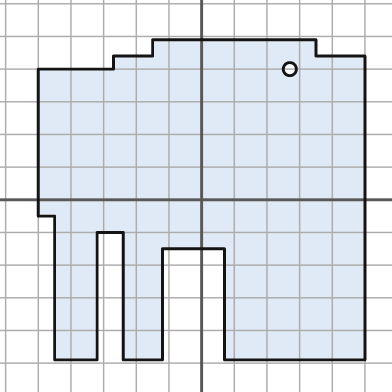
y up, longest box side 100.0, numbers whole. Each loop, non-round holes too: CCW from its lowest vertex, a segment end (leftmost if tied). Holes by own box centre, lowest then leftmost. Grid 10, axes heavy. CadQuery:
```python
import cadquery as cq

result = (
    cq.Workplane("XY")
    .moveTo(-45.0, -49.0)
    .lineTo(-32.0, -49.0)
    .lineTo(-32.0, -10.0)
    .lineTo(-24.0, -10.0)
    .lineTo(-24.0, -49.0)
    .lineTo(-12.0, -49.0)
    .lineTo(-12.0, -15.0)
    .lineTo(7.0, -15.0)
    .lineTo(7.0, -49.0)
    .lineTo(50.0, -49.0)
    .lineTo(50.0, 44.0)
    .lineTo(35.0, 44.0)
    .lineTo(35.0, 49.0)
    .lineTo(-15.0, 49.0)
    .lineTo(-15.0, 44.0)
    .lineTo(-27.0, 44.0)
    .lineTo(-27.0, 40.0)
    .lineTo(-50.0, 40.0)
    .lineTo(-50.0, -5.0)
    .lineTo(-45.0, -5.0)
    .close()
    .moveTo(27.0, 40.0)
    .circle(2.0)
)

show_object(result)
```